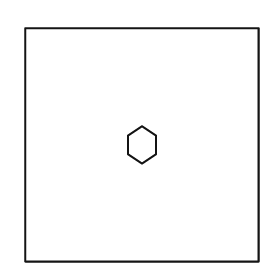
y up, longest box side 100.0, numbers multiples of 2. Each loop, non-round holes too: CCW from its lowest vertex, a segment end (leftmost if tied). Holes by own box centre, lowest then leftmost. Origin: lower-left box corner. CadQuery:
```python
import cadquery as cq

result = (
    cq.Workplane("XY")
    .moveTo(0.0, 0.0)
    .lineTo(100.0, 0.0)
    .lineTo(100.0, 100.0)
    .lineTo(0.0, 100.0)
    .close()
    .moveTo(50.0, 42.0)
    .lineTo(56.0, 46.0)
    .lineTo(56.0, 54.0)
    .lineTo(50.0, 58.0)
    .lineTo(44.0, 54.0)
    .lineTo(44.0, 46.0)
    .close()
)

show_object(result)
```